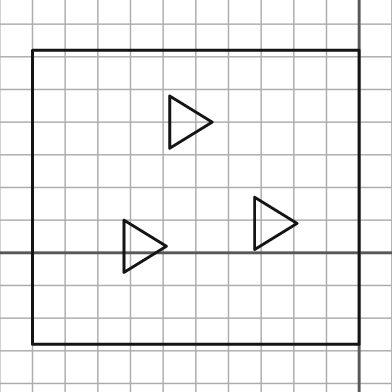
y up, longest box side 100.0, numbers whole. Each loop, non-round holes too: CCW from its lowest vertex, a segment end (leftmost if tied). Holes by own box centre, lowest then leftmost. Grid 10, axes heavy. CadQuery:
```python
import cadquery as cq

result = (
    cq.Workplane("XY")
    .moveTo(-100.0, -28.0)
    .lineTo(0.0, -28.0)
    .lineTo(0.0, 62.0)
    .lineTo(-100.0, 62.0)
    .close()
    .moveTo(-72.0, -6.0)
    .lineTo(-59.0, 2.0)
    .lineTo(-72.0, 10.0)
    .close()
    .moveTo(-32.0, 1.0)
    .lineTo(-19.0, 9.0)
    .lineTo(-32.0, 17.0)
    .close()
    .moveTo(-58.0, 32.0)
    .lineTo(-45.0, 40.0)
    .lineTo(-58.0, 48.0)
    .close()
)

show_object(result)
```